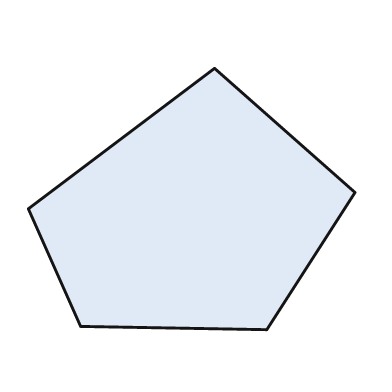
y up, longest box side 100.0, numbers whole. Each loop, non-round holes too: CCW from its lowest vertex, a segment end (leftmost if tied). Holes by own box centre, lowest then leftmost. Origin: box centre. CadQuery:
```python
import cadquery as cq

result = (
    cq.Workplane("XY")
    .moveTo(23.0, -40.0)
    .lineTo(50.0, 2.0)
    .lineTo(7.0, 40.0)
    .lineTo(-50.0, -3.0)
    .lineTo(-34.0, -39.0)
    .close()
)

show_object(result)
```